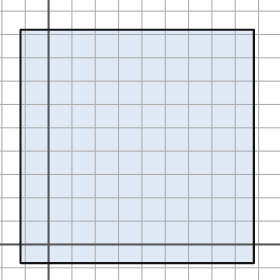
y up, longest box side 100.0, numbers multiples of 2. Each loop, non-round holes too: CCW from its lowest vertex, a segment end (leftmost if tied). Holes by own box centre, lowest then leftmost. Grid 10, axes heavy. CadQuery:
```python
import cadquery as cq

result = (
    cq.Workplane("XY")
    .moveTo(-12.0, -8.0)
    .lineTo(88.0, -8.0)
    .lineTo(88.0, 92.0)
    .lineTo(-12.0, 92.0)
    .close()
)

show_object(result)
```